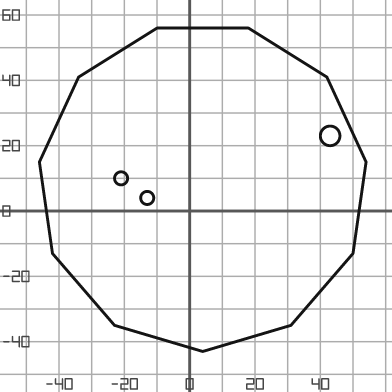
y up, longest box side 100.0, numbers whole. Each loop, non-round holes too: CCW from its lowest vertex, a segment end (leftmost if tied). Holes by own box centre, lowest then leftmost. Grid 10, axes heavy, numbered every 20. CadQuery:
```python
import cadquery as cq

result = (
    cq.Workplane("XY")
    .moveTo(4.0, -43.0)
    .lineTo(31.0, -35.0)
    .lineTo(50.0, -13.0)
    .lineTo(54.0, 15.0)
    .lineTo(42.0, 41.0)
    .lineTo(18.0, 56.0)
    .lineTo(-10.0, 56.0)
    .lineTo(-34.0, 41.0)
    .lineTo(-46.0, 15.0)
    .lineTo(-42.0, -13.0)
    .lineTo(-23.0, -35.0)
    .close()
    .moveTo(-13.0, 4.0)
    .circle(2.0)
    .moveTo(-21.0, 10.0)
    .circle(2.0)
    .moveTo(43.0, 23.0)
    .circle(3.0)
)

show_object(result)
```